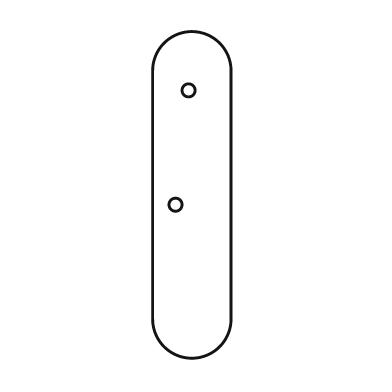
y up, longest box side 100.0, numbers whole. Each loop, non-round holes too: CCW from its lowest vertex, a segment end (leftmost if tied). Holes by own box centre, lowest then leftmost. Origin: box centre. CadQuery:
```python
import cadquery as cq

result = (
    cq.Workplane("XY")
    .moveTo(-12.0, -38.0)
    .threePointArc((0.0, -50.0), (12.0, -38.0))
    .lineTo(12.0, 38.0)
    .threePointArc((0.0, 50.0), (-12.0, 38.0))
    .close()
    .moveTo(-5.0, -3.0)
    .circle(2.0)
    .moveTo(-1.0, 32.0)
    .circle(2.0)
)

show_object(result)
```